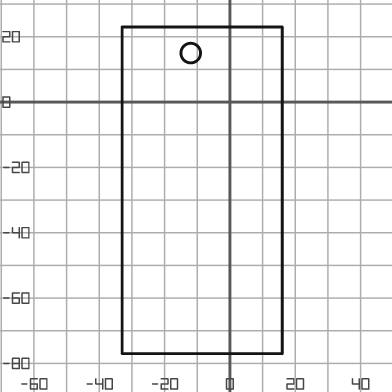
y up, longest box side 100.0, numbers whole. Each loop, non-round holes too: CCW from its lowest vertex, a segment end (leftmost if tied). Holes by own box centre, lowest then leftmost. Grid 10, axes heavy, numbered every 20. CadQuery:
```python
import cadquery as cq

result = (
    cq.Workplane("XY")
    .moveTo(-33.0, -77.0)
    .lineTo(16.0, -77.0)
    .lineTo(16.0, 23.0)
    .lineTo(-33.0, 23.0)
    .close()
    .moveTo(-12.0, 15.0)
    .circle(3.0)
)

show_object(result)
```